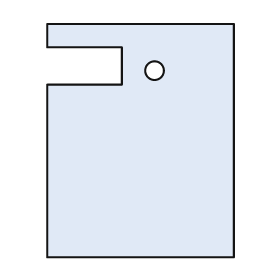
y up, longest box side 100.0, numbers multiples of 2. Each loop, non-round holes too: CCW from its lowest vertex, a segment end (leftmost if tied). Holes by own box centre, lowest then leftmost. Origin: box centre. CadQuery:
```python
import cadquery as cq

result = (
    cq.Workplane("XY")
    .moveTo(-40.0, -50.0)
    .lineTo(40.0, -50.0)
    .lineTo(40.0, 50.0)
    .lineTo(-40.0, 50.0)
    .lineTo(-40.0, 40.0)
    .lineTo(-8.0, 40.0)
    .lineTo(-8.0, 24.0)
    .lineTo(-40.0, 24.0)
    .close()
    .moveTo(6.0, 30.0)
    .circle(4.0)
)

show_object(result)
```